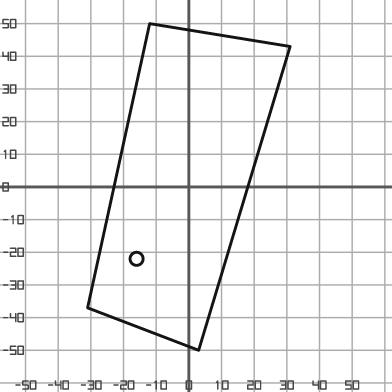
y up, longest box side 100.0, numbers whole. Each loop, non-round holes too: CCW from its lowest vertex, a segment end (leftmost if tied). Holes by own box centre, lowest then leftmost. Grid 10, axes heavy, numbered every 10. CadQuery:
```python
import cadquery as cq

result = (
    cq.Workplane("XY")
    .moveTo(3.0, -50.0)
    .lineTo(31.0, 43.0)
    .lineTo(-12.0, 50.0)
    .lineTo(-31.0, -37.0)
    .close()
    .moveTo(-16.0, -22.0)
    .circle(2.0)
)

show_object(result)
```